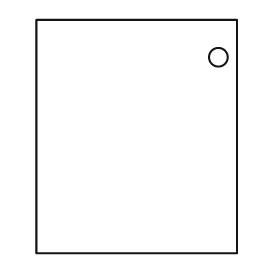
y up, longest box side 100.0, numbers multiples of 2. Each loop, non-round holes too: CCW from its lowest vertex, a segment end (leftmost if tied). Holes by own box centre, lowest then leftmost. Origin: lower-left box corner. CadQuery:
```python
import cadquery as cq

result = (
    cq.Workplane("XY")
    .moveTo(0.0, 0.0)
    .lineTo(86.0, 0.0)
    .lineTo(86.0, 100.0)
    .lineTo(0.0, 100.0)
    .close()
    .moveTo(78.0, 84.0)
    .circle(4.0)
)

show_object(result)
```